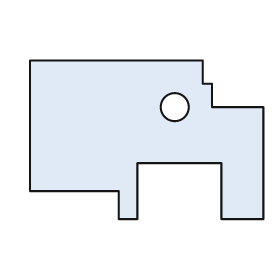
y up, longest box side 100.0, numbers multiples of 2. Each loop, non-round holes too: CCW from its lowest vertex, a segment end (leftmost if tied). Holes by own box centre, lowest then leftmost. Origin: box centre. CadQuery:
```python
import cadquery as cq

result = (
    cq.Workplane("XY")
    .moveTo(-12.0, -34.0)
    .lineTo(-4.0, -34.0)
    .lineTo(-4.0, -10.0)
    .lineTo(32.0, -10.0)
    .lineTo(32.0, -34.0)
    .lineTo(50.0, -34.0)
    .lineTo(50.0, 14.0)
    .lineTo(28.0, 14.0)
    .lineTo(28.0, 24.0)
    .lineTo(24.0, 24.0)
    .lineTo(24.0, 34.0)
    .lineTo(-50.0, 34.0)
    .lineTo(-50.0, -22.0)
    .lineTo(-12.0, -22.0)
    .close()
    .moveTo(12.0, 14.0)
    .circle(6.0)
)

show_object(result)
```